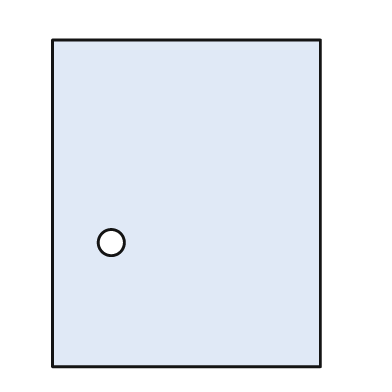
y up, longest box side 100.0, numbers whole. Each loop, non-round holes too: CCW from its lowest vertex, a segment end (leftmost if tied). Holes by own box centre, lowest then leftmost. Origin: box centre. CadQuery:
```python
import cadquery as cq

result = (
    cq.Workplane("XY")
    .moveTo(-41.0, -50.0)
    .lineTo(41.0, -50.0)
    .lineTo(41.0, 50.0)
    .lineTo(-41.0, 50.0)
    .close()
    .moveTo(-23.0, -12.0)
    .circle(4.0)
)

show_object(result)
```